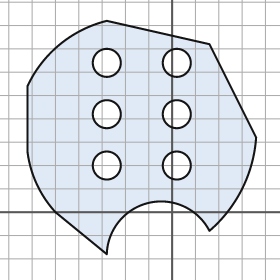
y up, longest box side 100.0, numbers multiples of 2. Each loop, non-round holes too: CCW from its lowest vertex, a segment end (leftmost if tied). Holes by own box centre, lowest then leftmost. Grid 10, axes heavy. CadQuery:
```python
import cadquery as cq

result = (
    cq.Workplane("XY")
    .moveTo(-28.0, -18.0)
    .threePointArc((-10.0, 4.0), (16.0, -8.0))
    .threePointArc((30.0, 10.0), (36.0, 32.0))
    .lineTo(16.0, 72.0)
    .lineTo(-28.0, 82.0)
    .threePointArc((-48.0, 72.0), (-62.0, 54.0))
    .lineTo(-62.0, 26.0)
    .threePointArc((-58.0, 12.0), (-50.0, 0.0))
    .close()
    .moveTo(-28.0, 20.0)
    .circle(6.0)
    .moveTo(2.0, 20.0)
    .circle(6.0)
    .moveTo(-28.0, 42.0)
    .circle(6.0)
    .moveTo(2.0, 42.0)
    .circle(6.0)
    .moveTo(-28.0, 64.0)
    .circle(6.0)
    .moveTo(2.0, 64.0)
    .circle(6.0)
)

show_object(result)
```